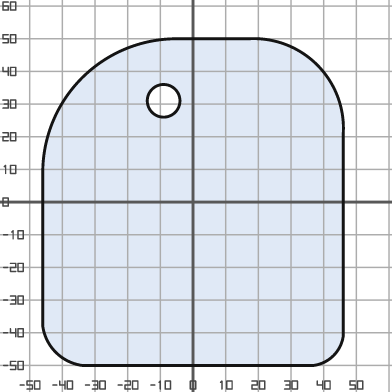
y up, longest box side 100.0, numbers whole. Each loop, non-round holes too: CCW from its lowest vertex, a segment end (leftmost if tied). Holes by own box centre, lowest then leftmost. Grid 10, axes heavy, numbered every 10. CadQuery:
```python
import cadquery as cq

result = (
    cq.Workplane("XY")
    .moveTo(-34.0, -50.0)
    .lineTo(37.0, -50.0)
    .threePointArc((43.0, -47.0), (46.0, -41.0))
    .lineTo(46.0, 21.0)
    .threePointArc((38.0, 42.0), (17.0, 50.0))
    .lineTo(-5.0, 50.0)
    .threePointArc((-34.0, 38.0), (-46.0, 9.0))
    .lineTo(-46.0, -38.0)
    .threePointArc((-42.0, -46.0), (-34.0, -50.0))
    .close()
    .moveTo(-9.0, 31.0)
    .circle(5.0)
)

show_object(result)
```